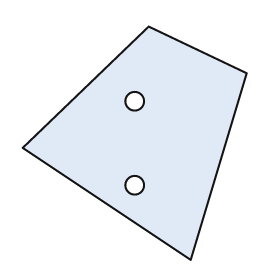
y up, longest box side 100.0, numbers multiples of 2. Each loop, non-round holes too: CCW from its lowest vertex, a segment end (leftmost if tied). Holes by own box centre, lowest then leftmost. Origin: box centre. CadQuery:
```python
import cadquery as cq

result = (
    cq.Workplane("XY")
    .moveTo(24.0, -50.0)
    .lineTo(48.0, 30.0)
    .lineTo(6.0, 50.0)
    .lineTo(-48.0, -2.0)
    .close()
    .moveTo(0.0, -18.0)
    .circle(4.0)
    .moveTo(0.0, 18.0)
    .circle(4.0)
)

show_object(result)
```